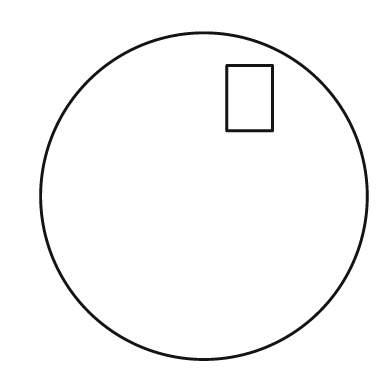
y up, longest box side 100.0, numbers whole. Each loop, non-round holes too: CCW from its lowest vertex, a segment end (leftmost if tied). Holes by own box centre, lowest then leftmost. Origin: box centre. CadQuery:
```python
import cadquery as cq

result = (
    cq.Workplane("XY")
    .moveTo(0.0, 0.0)
    .circle(50.0)
    .moveTo(7.0, 20.0)
    .lineTo(21.0, 20.0)
    .lineTo(21.0, 40.0)
    .lineTo(7.0, 40.0)
    .close()
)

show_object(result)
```